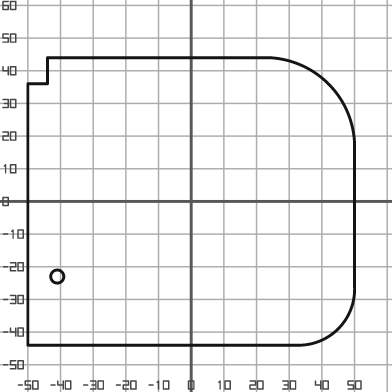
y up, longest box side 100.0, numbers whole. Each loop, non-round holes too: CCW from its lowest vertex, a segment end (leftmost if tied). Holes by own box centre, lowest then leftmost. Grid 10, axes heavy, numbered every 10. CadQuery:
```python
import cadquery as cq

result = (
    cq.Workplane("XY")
    .moveTo(-50.0, -44.0)
    .lineTo(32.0, -44.0)
    .threePointArc((45.0, -39.0), (50.0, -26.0))
    .lineTo(50.0, 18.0)
    .threePointArc((42.0, 36.0), (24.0, 44.0))
    .lineTo(-44.0, 44.0)
    .lineTo(-44.0, 36.0)
    .lineTo(-50.0, 36.0)
    .close()
    .moveTo(-41.0, -23.0)
    .circle(2.0)
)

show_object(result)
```